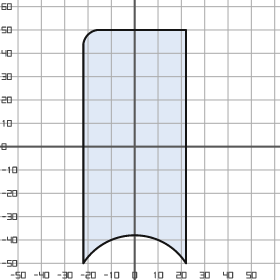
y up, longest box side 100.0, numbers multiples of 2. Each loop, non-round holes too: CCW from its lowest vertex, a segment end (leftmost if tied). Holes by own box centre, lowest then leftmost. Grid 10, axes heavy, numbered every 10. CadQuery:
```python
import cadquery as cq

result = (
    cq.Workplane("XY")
    .moveTo(-22.0, -50.0)
    .threePointArc((0.0, -38.0), (22.0, -50.0))
    .lineTo(22.0, 50.0)
    .lineTo(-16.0, 50.0)
    .threePointArc((-20.0, 48.0), (-22.0, 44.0))
    .close()
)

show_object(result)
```